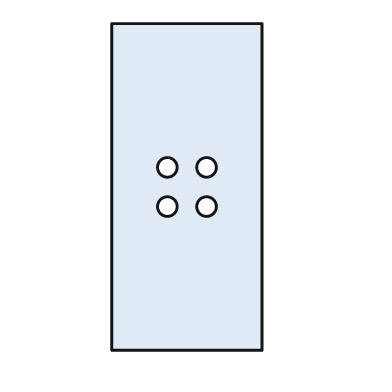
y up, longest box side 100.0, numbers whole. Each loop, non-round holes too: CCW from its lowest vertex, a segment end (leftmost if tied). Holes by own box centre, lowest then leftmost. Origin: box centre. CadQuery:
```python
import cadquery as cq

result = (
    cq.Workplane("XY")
    .moveTo(-23.0, -50.0)
    .lineTo(23.0, -50.0)
    .lineTo(23.0, 50.0)
    .lineTo(-23.0, 50.0)
    .close()
    .moveTo(-6.0, -6.0)
    .circle(3.0)
    .moveTo(6.0, -6.0)
    .circle(3.0)
    .moveTo(-6.0, 6.0)
    .circle(3.0)
    .moveTo(6.0, 6.0)
    .circle(3.0)
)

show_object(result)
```